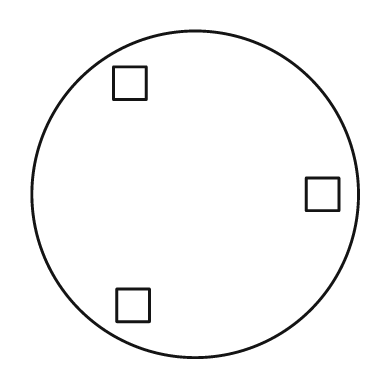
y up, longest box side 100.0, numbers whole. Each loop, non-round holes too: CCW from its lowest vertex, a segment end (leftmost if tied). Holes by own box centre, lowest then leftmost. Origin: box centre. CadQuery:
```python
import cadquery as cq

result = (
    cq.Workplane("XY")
    .moveTo(0.0, 0.0)
    .circle(50.0)
    .moveTo(-24.0, -39.0)
    .lineTo(-14.0, -39.0)
    .lineTo(-14.0, -29.0)
    .lineTo(-24.0, -29.0)
    .close()
    .moveTo(34.0, -5.0)
    .lineTo(44.0, -5.0)
    .lineTo(44.0, 5.0)
    .lineTo(34.0, 5.0)
    .close()
    .moveTo(-25.0, 29.0)
    .lineTo(-15.0, 29.0)
    .lineTo(-15.0, 39.0)
    .lineTo(-25.0, 39.0)
    .close()
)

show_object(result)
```